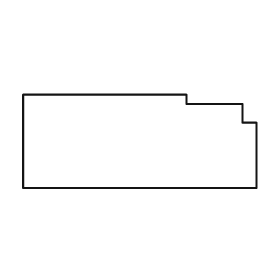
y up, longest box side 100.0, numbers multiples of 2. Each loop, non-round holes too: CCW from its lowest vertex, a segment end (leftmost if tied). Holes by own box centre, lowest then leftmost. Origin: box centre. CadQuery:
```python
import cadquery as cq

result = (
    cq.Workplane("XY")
    .moveTo(-50.0, -20.0)
    .lineTo(50.0, -20.0)
    .lineTo(50.0, 8.0)
    .lineTo(44.0, 8.0)
    .lineTo(44.0, 16.0)
    .lineTo(20.0, 16.0)
    .lineTo(20.0, 20.0)
    .lineTo(-50.0, 20.0)
    .close()
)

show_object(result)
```